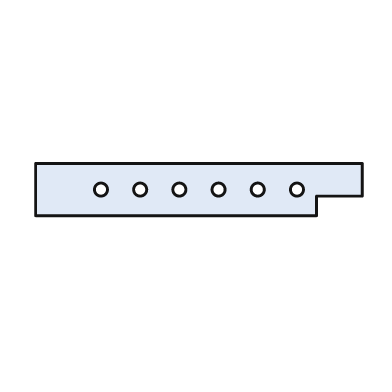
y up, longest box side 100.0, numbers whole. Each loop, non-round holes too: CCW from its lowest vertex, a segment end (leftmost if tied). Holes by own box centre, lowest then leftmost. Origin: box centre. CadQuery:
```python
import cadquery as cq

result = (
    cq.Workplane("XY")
    .moveTo(-50.0, -8.0)
    .lineTo(36.0, -8.0)
    .lineTo(36.0, -2.0)
    .lineTo(50.0, -2.0)
    .lineTo(50.0, 8.0)
    .lineTo(-50.0, 8.0)
    .close()
    .moveTo(-30.0, 0.0)
    .circle(2.0)
    .moveTo(-18.0, 0.0)
    .circle(2.0)
    .moveTo(-6.0, 0.0)
    .circle(2.0)
    .moveTo(6.0, 0.0)
    .circle(2.0)
    .moveTo(18.0, 0.0)
    .circle(2.0)
    .moveTo(30.0, 0.0)
    .circle(2.0)
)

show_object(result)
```